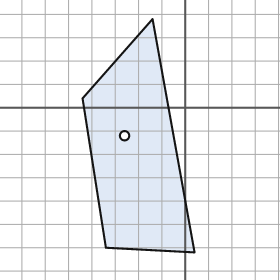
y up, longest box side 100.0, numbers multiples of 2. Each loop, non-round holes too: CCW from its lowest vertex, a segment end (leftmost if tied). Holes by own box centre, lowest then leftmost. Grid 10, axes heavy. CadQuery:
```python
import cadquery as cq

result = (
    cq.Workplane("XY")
    .moveTo(4.0, -62.0)
    .lineTo(-14.0, 38.0)
    .lineTo(-44.0, 4.0)
    .lineTo(-34.0, -60.0)
    .close()
    .moveTo(-26.0, -12.0)
    .circle(2.0)
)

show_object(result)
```